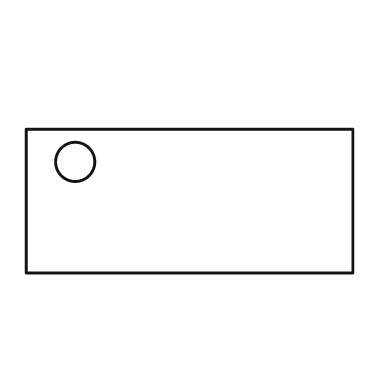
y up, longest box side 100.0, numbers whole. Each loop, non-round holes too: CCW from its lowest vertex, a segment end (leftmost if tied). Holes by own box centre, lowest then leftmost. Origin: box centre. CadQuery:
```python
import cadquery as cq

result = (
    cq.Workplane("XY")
    .moveTo(-50.0, -22.0)
    .lineTo(50.0, -22.0)
    .lineTo(50.0, 22.0)
    .lineTo(-50.0, 22.0)
    .close()
    .moveTo(-35.0, 12.0)
    .circle(6.0)
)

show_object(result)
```